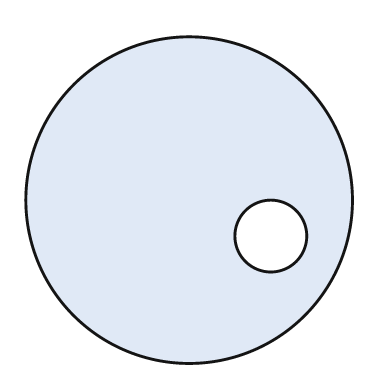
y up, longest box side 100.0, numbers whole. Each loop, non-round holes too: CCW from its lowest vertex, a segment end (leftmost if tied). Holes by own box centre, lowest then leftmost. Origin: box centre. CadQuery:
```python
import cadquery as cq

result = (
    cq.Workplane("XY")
    .moveTo(0.0, 0.0)
    .circle(50.0)
    .moveTo(25.0, -11.0)
    .circle(11.0)
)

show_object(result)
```